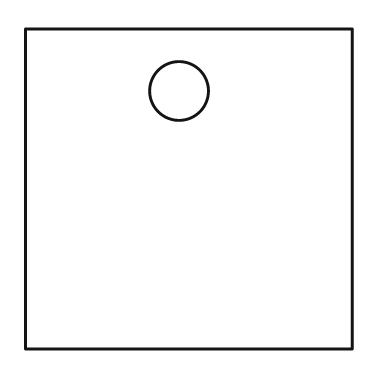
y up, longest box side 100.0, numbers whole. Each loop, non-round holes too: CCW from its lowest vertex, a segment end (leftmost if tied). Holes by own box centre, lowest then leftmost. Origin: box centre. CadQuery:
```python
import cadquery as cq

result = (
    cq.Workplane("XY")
    .moveTo(-50.0, -49.0)
    .lineTo(50.0, -49.0)
    .lineTo(50.0, 49.0)
    .lineTo(-50.0, 49.0)
    .close()
    .moveTo(-3.0, 30.0)
    .circle(9.0)
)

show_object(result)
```